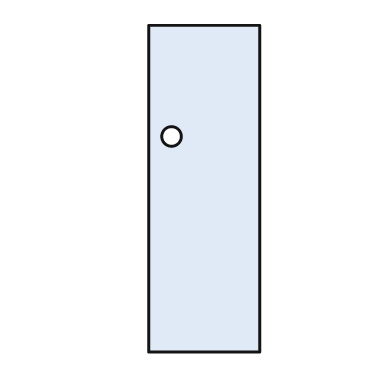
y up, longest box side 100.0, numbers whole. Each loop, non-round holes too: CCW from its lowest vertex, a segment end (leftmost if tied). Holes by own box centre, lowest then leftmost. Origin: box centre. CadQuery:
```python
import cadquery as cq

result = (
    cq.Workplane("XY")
    .moveTo(-17.0, -50.0)
    .lineTo(17.0, -50.0)
    .lineTo(17.0, 50.0)
    .lineTo(-17.0, 50.0)
    .close()
    .moveTo(-10.0, 16.0)
    .circle(3.0)
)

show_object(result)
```